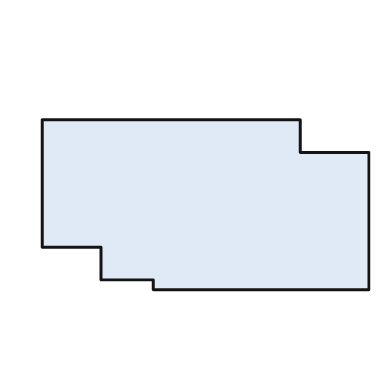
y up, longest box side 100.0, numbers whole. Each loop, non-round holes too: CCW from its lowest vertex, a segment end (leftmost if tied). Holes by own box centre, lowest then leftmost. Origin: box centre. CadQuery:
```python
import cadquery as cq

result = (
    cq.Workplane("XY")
    .moveTo(-16.0, -26.0)
    .lineTo(50.0, -26.0)
    .lineTo(50.0, 16.0)
    .lineTo(29.0, 16.0)
    .lineTo(29.0, 26.0)
    .lineTo(-50.0, 26.0)
    .lineTo(-50.0, -13.0)
    .lineTo(-32.0, -13.0)
    .lineTo(-32.0, -23.0)
    .lineTo(-16.0, -23.0)
    .close()
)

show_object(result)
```